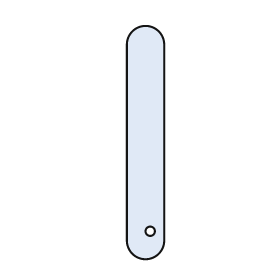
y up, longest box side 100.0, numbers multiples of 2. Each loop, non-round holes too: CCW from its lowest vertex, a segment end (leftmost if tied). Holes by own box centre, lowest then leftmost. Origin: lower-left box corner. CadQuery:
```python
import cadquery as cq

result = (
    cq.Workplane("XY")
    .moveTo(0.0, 8.0)
    .threePointArc((8.0, 0.0), (16.0, 8.0))
    .lineTo(16.0, 92.0)
    .threePointArc((8.0, 100.0), (0.0, 92.0))
    .close()
    .moveTo(10.0, 12.0)
    .circle(2.0)
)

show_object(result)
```